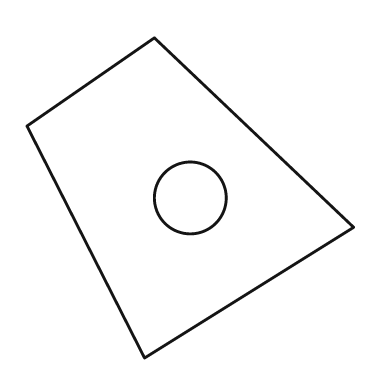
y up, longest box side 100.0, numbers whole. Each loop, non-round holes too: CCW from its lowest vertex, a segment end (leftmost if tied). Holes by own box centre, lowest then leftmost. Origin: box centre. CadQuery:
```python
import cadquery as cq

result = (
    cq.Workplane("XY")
    .moveTo(-14.0, -49.0)
    .lineTo(50.0, -9.0)
    .lineTo(-11.0, 49.0)
    .lineTo(-50.0, 22.0)
    .close()
    .moveTo(0.0, 0.0)
    .circle(11.0)
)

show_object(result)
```